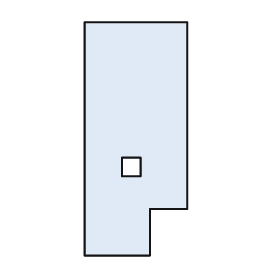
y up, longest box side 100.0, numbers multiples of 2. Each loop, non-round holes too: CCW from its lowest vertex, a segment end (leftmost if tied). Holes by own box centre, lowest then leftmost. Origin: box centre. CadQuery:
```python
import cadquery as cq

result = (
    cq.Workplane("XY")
    .moveTo(-22.0, -50.0)
    .lineTo(6.0, -50.0)
    .lineTo(6.0, -30.0)
    .lineTo(22.0, -30.0)
    .lineTo(22.0, 50.0)
    .lineTo(-22.0, 50.0)
    .close()
    .moveTo(-6.0, -16.0)
    .lineTo(2.0, -16.0)
    .lineTo(2.0, -8.0)
    .lineTo(-6.0, -8.0)
    .close()
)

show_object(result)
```